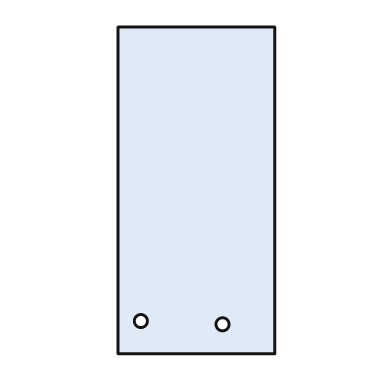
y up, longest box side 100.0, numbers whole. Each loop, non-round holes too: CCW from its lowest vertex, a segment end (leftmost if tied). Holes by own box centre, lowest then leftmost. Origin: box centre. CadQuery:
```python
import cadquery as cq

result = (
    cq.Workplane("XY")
    .moveTo(-24.0, -50.0)
    .lineTo(24.0, -50.0)
    .lineTo(24.0, 50.0)
    .lineTo(-24.0, 50.0)
    .close()
    .moveTo(8.0, -41.0)
    .circle(2.0)
    .moveTo(-17.0, -40.0)
    .circle(2.0)
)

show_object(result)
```